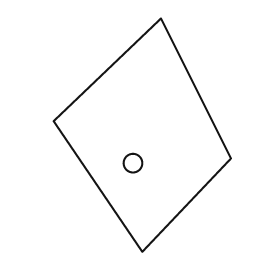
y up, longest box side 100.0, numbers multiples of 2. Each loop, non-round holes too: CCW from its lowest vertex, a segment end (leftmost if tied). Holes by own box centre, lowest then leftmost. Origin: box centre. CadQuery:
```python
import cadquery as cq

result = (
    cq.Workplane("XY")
    .moveTo(0.0, -50.0)
    .lineTo(38.0, -10.0)
    .lineTo(8.0, 50.0)
    .lineTo(-38.0, 6.0)
    .close()
    .moveTo(-4.0, -12.0)
    .circle(4.0)
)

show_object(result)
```